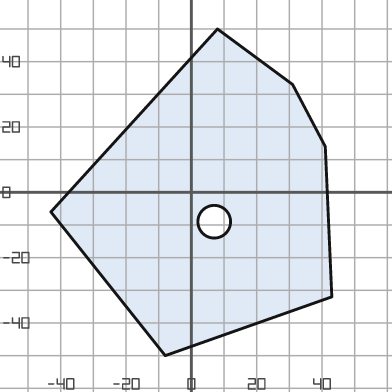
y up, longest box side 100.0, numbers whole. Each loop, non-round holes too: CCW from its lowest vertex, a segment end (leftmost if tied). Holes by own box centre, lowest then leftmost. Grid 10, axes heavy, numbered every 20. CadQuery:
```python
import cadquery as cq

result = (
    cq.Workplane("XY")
    .moveTo(-8.0, -50.0)
    .lineTo(43.0, -32.0)
    .lineTo(41.0, 14.0)
    .lineTo(31.0, 33.0)
    .lineTo(8.0, 50.0)
    .lineTo(-43.0, -6.0)
    .close()
    .moveTo(7.0, -9.0)
    .circle(5.0)
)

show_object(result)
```